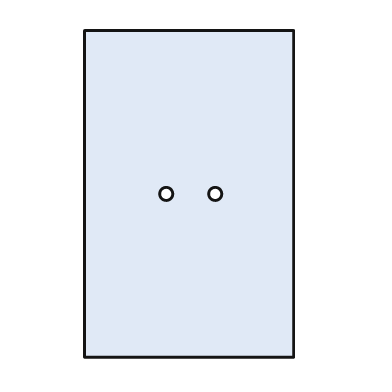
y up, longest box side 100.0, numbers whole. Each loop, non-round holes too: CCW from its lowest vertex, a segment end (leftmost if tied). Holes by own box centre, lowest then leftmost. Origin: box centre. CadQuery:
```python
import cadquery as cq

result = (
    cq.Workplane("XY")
    .moveTo(-32.0, -50.0)
    .lineTo(32.0, -50.0)
    .lineTo(32.0, 50.0)
    .lineTo(-32.0, 50.0)
    .close()
    .moveTo(-7.0, 0.0)
    .circle(2.0)
    .moveTo(8.0, 0.0)
    .circle(2.0)
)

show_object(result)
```